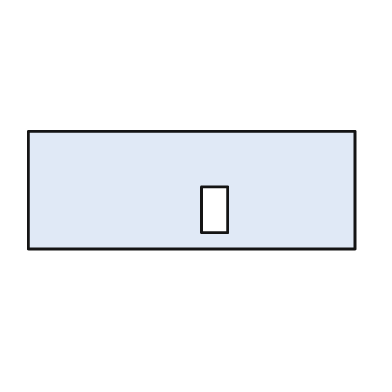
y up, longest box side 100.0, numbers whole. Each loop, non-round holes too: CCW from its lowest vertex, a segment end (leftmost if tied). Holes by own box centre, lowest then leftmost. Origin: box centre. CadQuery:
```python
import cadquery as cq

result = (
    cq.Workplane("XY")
    .moveTo(-50.0, -18.0)
    .lineTo(50.0, -18.0)
    .lineTo(50.0, 18.0)
    .lineTo(-50.0, 18.0)
    .close()
    .moveTo(3.0, -13.0)
    .lineTo(11.0, -13.0)
    .lineTo(11.0, 1.0)
    .lineTo(3.0, 1.0)
    .close()
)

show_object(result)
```